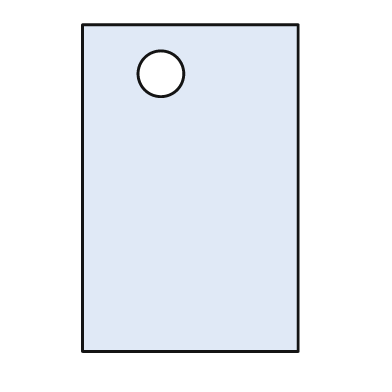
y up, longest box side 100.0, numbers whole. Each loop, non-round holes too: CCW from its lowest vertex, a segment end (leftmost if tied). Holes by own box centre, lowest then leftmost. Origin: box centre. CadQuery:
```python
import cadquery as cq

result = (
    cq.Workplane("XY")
    .moveTo(-33.0, -50.0)
    .lineTo(33.0, -50.0)
    .lineTo(33.0, 50.0)
    .lineTo(-33.0, 50.0)
    .close()
    .moveTo(-9.0, 35.0)
    .circle(7.0)
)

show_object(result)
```